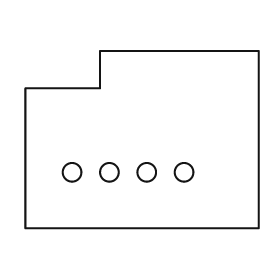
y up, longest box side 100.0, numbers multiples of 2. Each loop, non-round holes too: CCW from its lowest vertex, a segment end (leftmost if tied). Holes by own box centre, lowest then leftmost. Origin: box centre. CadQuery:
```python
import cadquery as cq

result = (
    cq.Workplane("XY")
    .moveTo(-50.0, -38.0)
    .lineTo(50.0, -38.0)
    .lineTo(50.0, 38.0)
    .lineTo(-18.0, 38.0)
    .lineTo(-18.0, 22.0)
    .lineTo(-50.0, 22.0)
    .close()
    .moveTo(-30.0, -14.0)
    .circle(4.0)
    .moveTo(-14.0, -14.0)
    .circle(4.0)
    .moveTo(2.0, -14.0)
    .circle(4.0)
    .moveTo(18.0, -14.0)
    .circle(4.0)
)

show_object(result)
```